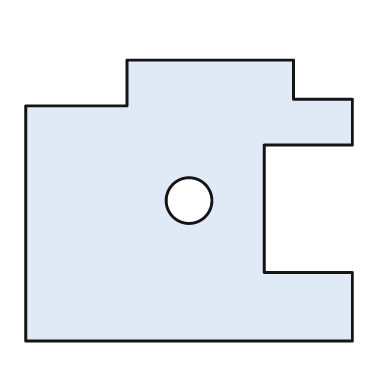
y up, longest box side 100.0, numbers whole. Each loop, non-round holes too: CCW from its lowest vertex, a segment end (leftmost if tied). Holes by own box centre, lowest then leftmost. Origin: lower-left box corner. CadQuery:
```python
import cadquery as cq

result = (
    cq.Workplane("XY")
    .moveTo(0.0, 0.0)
    .lineTo(100.0, 0.0)
    .lineTo(100.0, 21.0)
    .lineTo(73.0, 21.0)
    .lineTo(73.0, 60.0)
    .lineTo(100.0, 60.0)
    .lineTo(100.0, 74.0)
    .lineTo(82.0, 74.0)
    .lineTo(82.0, 86.0)
    .lineTo(31.0, 86.0)
    .lineTo(31.0, 72.0)
    .lineTo(0.0, 72.0)
    .close()
    .moveTo(50.0, 43.0)
    .circle(7.0)
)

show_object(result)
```